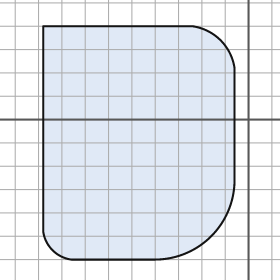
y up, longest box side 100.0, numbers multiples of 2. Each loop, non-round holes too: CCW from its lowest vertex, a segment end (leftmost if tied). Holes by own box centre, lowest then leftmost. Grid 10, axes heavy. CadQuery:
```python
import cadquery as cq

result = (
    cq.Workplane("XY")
    .moveTo(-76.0, -60.0)
    .lineTo(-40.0, -60.0)
    .threePointArc((-16.0, -50.0), (-6.0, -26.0))
    .lineTo(-6.0, 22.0)
    .threePointArc((-12.0, 34.0), (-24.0, 40.0))
    .lineTo(-88.0, 40.0)
    .lineTo(-88.0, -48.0)
    .threePointArc((-84.0, -56.0), (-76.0, -60.0))
    .close()
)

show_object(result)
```